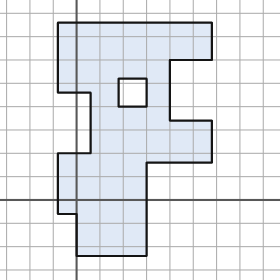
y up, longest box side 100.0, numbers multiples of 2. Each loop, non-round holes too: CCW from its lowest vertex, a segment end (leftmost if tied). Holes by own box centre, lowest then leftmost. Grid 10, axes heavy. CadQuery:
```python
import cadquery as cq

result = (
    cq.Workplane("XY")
    .moveTo(0.0, -24.0)
    .lineTo(30.0, -24.0)
    .lineTo(30.0, 16.0)
    .lineTo(58.0, 16.0)
    .lineTo(58.0, 34.0)
    .lineTo(40.0, 34.0)
    .lineTo(40.0, 60.0)
    .lineTo(58.0, 60.0)
    .lineTo(58.0, 76.0)
    .lineTo(-8.0, 76.0)
    .lineTo(-8.0, 46.0)
    .lineTo(6.0, 46.0)
    .lineTo(6.0, 20.0)
    .lineTo(-8.0, 20.0)
    .lineTo(-8.0, -6.0)
    .lineTo(0.0, -6.0)
    .close()
    .moveTo(18.0, 40.0)
    .lineTo(30.0, 40.0)
    .lineTo(30.0, 52.0)
    .lineTo(18.0, 52.0)
    .close()
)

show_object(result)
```